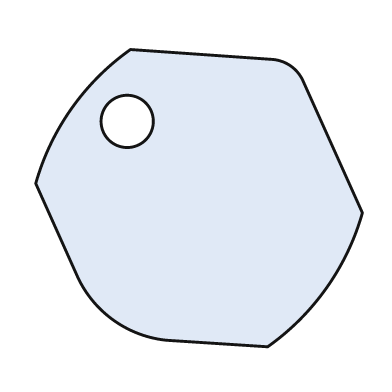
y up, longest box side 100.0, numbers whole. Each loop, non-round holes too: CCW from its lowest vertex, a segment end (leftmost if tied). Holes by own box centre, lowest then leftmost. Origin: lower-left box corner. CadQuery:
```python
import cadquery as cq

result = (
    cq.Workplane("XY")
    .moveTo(71.0, 0.0)
    .threePointArc((89.0, 18.0), (100.0, 41.0))
    .lineTo(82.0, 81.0)
    .threePointArc((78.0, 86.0), (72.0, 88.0))
    .lineTo(29.0, 91.0)
    .threePointArc((11.0, 73.0), (0.0, 50.0))
    .lineTo(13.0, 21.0)
    .threePointArc((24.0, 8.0), (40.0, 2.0))
    .close()
    .moveTo(28.0, 69.0)
    .circle(8.0)
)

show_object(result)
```